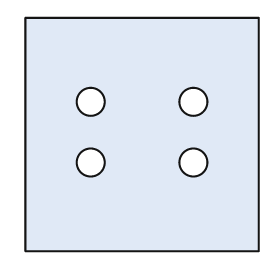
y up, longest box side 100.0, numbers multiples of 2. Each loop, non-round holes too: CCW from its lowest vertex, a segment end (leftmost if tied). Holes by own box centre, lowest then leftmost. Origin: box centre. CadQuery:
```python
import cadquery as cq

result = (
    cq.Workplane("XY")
    .moveTo(-50.0, -50.0)
    .lineTo(50.0, -50.0)
    .lineTo(50.0, 50.0)
    .lineTo(-50.0, 50.0)
    .close()
    .moveTo(-22.0, -12.0)
    .circle(6.0)
    .moveTo(22.0, -12.0)
    .circle(6.0)
    .moveTo(-22.0, 14.0)
    .circle(6.0)
    .moveTo(22.0, 14.0)
    .circle(6.0)
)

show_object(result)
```